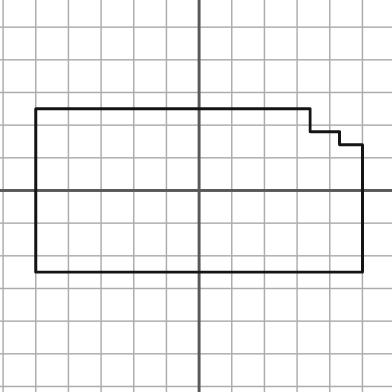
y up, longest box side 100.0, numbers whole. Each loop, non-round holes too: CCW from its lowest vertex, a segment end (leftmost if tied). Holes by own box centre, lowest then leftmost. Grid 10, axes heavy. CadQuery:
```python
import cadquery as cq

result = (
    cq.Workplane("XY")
    .moveTo(-50.0, -25.0)
    .lineTo(50.0, -25.0)
    .lineTo(50.0, 14.0)
    .lineTo(43.0, 14.0)
    .lineTo(43.0, 18.0)
    .lineTo(34.0, 18.0)
    .lineTo(34.0, 25.0)
    .lineTo(-50.0, 25.0)
    .close()
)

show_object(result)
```